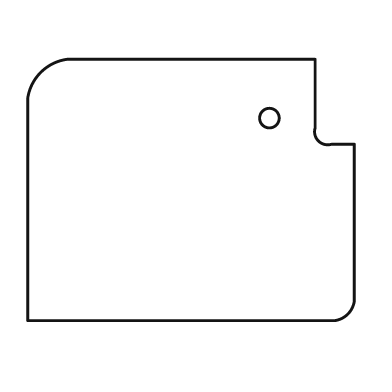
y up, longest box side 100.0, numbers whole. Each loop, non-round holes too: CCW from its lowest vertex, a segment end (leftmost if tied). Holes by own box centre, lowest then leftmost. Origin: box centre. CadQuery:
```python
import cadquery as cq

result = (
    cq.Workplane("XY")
    .moveTo(-50.0, -40.0)
    .lineTo(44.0, -40.0)
    .threePointArc((48.0, -38.0), (50.0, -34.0))
    .lineTo(50.0, 14.0)
    .lineTo(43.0, 14.0)
    .threePointArc((39.0, 15.0), (38.0, 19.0))
    .lineTo(38.0, 40.0)
    .lineTo(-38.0, 40.0)
    .threePointArc((-46.0, 36.0), (-50.0, 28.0))
    .close()
    .moveTo(24.0, 22.0)
    .circle(3.0)
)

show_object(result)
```